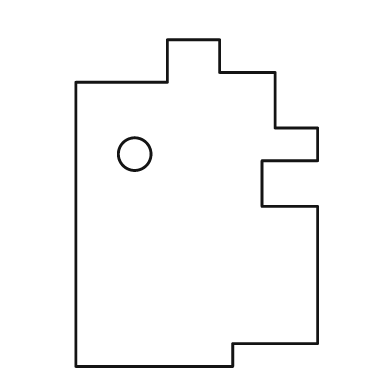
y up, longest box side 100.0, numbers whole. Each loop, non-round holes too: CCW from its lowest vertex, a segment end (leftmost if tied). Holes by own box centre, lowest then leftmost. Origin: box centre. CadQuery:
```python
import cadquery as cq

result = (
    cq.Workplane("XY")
    .moveTo(-37.0, -50.0)
    .lineTo(11.0, -50.0)
    .lineTo(11.0, -43.0)
    .lineTo(37.0, -43.0)
    .lineTo(37.0, -1.0)
    .lineTo(20.0, -1.0)
    .lineTo(20.0, 13.0)
    .lineTo(37.0, 13.0)
    .lineTo(37.0, 23.0)
    .lineTo(24.0, 23.0)
    .lineTo(24.0, 40.0)
    .lineTo(7.0, 40.0)
    .lineTo(7.0, 50.0)
    .lineTo(-9.0, 50.0)
    .lineTo(-9.0, 37.0)
    .lineTo(-37.0, 37.0)
    .close()
    .moveTo(-19.0, 15.0)
    .circle(5.0)
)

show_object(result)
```